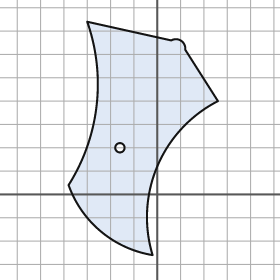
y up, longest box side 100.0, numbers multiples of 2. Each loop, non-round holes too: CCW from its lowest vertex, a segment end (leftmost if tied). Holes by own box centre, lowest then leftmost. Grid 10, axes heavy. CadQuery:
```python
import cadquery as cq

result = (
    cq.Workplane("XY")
    .moveTo(-2.0, -26.0)
    .threePointArc((0.0, 12.0), (26.0, 40.0))
    .lineTo(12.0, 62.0)
    .threePointArc((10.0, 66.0), (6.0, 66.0))
    .lineTo(-30.0, 74.0)
    .threePointArc((-26.0, 38.0), (-38.0, 4.0))
    .threePointArc((-24.0, -16.0), (-2.0, -26.0))
    .close()
    .moveTo(-16.0, 20.0)
    .circle(2.0)
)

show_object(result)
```